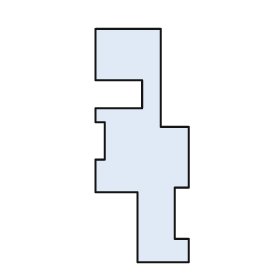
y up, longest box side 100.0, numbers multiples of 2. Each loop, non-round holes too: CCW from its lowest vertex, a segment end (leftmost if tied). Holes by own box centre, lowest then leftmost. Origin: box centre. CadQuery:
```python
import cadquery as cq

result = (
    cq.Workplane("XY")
    .moveTo(-2.0, -50.0)
    .lineTo(20.0, -50.0)
    .lineTo(20.0, -40.0)
    .lineTo(14.0, -40.0)
    .lineTo(14.0, -18.0)
    .lineTo(20.0, -18.0)
    .lineTo(20.0, 8.0)
    .lineTo(8.0, 8.0)
    .lineTo(8.0, 50.0)
    .lineTo(-20.0, 50.0)
    .lineTo(-20.0, 28.0)
    .lineTo(0.0, 28.0)
    .lineTo(0.0, 16.0)
    .lineTo(-20.0, 16.0)
    .lineTo(-20.0, 10.0)
    .lineTo(-16.0, 10.0)
    .lineTo(-16.0, -6.0)
    .lineTo(-20.0, -6.0)
    .lineTo(-20.0, -20.0)
    .lineTo(-2.0, -20.0)
    .close()
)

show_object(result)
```